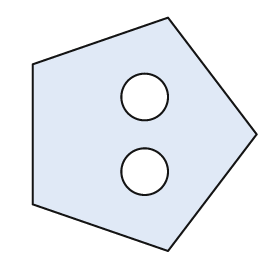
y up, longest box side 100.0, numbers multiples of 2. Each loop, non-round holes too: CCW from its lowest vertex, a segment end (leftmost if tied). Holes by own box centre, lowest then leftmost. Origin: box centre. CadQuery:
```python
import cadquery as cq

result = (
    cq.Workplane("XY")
    .moveTo(10.0, -50.0)
    .lineTo(48.0, 0.0)
    .lineTo(10.0, 50.0)
    .lineTo(-48.0, 30.0)
    .lineTo(-48.0, -30.0)
    .close()
    .moveTo(0.0, -16.0)
    .circle(10.0)
    .moveTo(0.0, 16.0)
    .circle(10.0)
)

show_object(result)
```